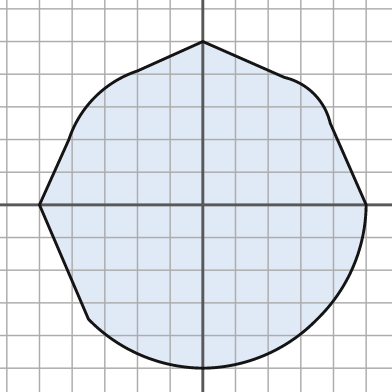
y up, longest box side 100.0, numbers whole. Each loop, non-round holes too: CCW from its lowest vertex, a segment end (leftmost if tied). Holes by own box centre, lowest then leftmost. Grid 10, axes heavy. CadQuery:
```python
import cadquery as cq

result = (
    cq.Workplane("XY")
    .moveTo(0.0, -50.0)
    .threePointArc((19.0, -46.0), (35.0, -35.0))
    .threePointArc((46.0, -19.0), (50.0, 0.0))
    .lineTo(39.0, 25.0)
    .threePointArc((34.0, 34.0), (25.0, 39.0))
    .lineTo(0.0, 50.0)
    .lineTo(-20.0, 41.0)
    .threePointArc((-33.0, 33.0), (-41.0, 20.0))
    .lineTo(-50.0, 0.0)
    .lineTo(-35.0, -35.0)
    .threePointArc((-19.0, -46.0), (0.0, -50.0))
    .close()
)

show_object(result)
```